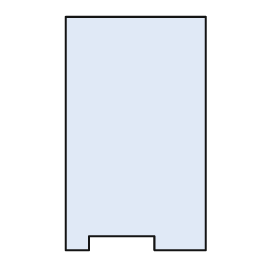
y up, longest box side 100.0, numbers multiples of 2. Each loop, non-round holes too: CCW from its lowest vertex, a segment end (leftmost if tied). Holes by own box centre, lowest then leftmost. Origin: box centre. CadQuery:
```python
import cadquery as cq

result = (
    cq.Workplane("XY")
    .moveTo(-30.0, -50.0)
    .lineTo(-20.0, -50.0)
    .lineTo(-20.0, -44.0)
    .lineTo(8.0, -44.0)
    .lineTo(8.0, -50.0)
    .lineTo(30.0, -50.0)
    .lineTo(30.0, 50.0)
    .lineTo(-30.0, 50.0)
    .close()
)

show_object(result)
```